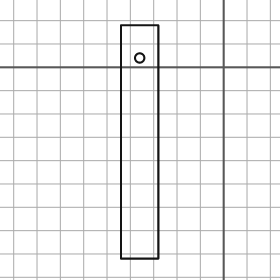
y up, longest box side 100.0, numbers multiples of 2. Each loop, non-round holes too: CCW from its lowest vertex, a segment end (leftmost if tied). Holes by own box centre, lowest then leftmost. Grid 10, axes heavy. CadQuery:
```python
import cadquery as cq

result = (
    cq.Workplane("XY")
    .moveTo(-44.0, -82.0)
    .lineTo(-28.0, -82.0)
    .lineTo(-28.0, 18.0)
    .lineTo(-44.0, 18.0)
    .close()
    .moveTo(-36.0, 4.0)
    .circle(2.0)
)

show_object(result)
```